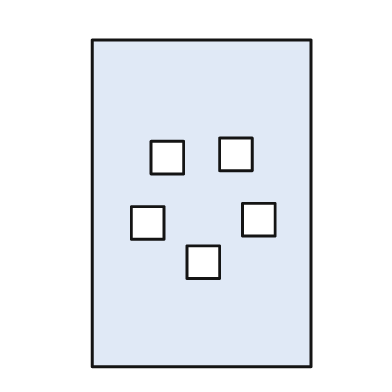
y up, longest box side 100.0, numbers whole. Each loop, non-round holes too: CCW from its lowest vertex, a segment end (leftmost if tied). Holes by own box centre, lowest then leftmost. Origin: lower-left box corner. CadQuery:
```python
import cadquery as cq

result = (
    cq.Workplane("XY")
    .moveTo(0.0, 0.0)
    .lineTo(67.0, 0.0)
    .lineTo(67.0, 100.0)
    .lineTo(0.0, 100.0)
    .close()
    .moveTo(29.0, 27.0)
    .lineTo(39.0, 27.0)
    .lineTo(39.0, 37.0)
    .lineTo(29.0, 37.0)
    .close()
    .moveTo(12.0, 39.0)
    .lineTo(22.0, 39.0)
    .lineTo(22.0, 49.0)
    .lineTo(12.0, 49.0)
    .close()
    .moveTo(46.0, 40.0)
    .lineTo(56.0, 40.0)
    .lineTo(56.0, 50.0)
    .lineTo(46.0, 50.0)
    .close()
    .moveTo(18.0, 59.0)
    .lineTo(28.0, 59.0)
    .lineTo(28.0, 69.0)
    .lineTo(18.0, 69.0)
    .close()
    .moveTo(39.0, 60.0)
    .lineTo(49.0, 60.0)
    .lineTo(49.0, 70.0)
    .lineTo(39.0, 70.0)
    .close()
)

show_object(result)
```